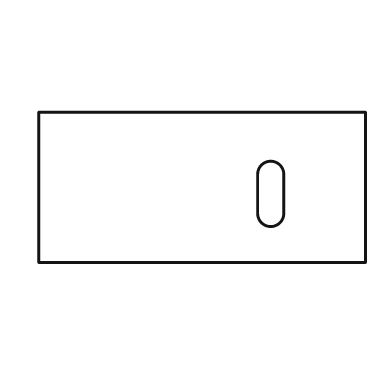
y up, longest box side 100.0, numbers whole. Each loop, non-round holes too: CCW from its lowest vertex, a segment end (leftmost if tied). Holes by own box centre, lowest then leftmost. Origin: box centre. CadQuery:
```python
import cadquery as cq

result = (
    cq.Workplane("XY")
    .moveTo(-50.0, -23.0)
    .lineTo(50.0, -23.0)
    .lineTo(50.0, 23.0)
    .lineTo(-50.0, 23.0)
    .close()
    .moveTo(17.0, -8.0)
    .threePointArc((21.0, -12.0), (25.0, -8.0))
    .lineTo(25.0, 4.0)
    .threePointArc((21.0, 8.0), (17.0, 4.0))
    .close()
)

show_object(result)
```